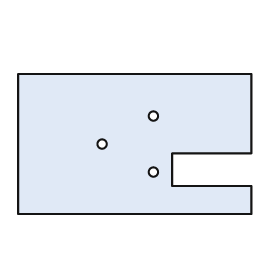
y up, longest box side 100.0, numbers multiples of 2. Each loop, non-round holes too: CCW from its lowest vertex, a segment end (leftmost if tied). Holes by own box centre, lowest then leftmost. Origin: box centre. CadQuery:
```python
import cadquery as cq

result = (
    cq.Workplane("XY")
    .moveTo(-50.0, -30.0)
    .lineTo(50.0, -30.0)
    .lineTo(50.0, -18.0)
    .lineTo(16.0, -18.0)
    .lineTo(16.0, -4.0)
    .lineTo(50.0, -4.0)
    .lineTo(50.0, 30.0)
    .lineTo(-50.0, 30.0)
    .close()
    .moveTo(8.0, -12.0)
    .circle(2.0)
    .moveTo(-14.0, 0.0)
    .circle(2.0)
    .moveTo(8.0, 12.0)
    .circle(2.0)
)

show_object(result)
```